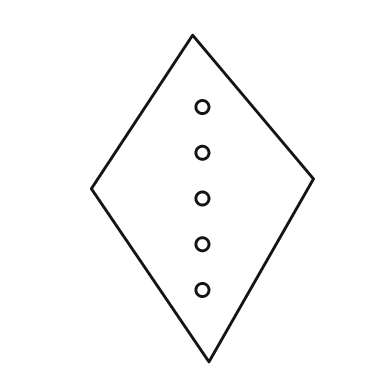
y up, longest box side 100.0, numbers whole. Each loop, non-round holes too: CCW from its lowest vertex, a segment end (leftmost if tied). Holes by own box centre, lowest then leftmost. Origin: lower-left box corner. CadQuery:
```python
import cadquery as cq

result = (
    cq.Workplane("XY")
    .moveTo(36.0, 0.0)
    .lineTo(68.0, 56.0)
    .lineTo(31.0, 100.0)
    .lineTo(0.0, 53.0)
    .close()
    .moveTo(34.0, 22.0)
    .circle(2.0)
    .moveTo(34.0, 36.0)
    .circle(2.0)
    .moveTo(34.0, 50.0)
    .circle(2.0)
    .moveTo(34.0, 64.0)
    .circle(2.0)
    .moveTo(34.0, 78.0)
    .circle(2.0)
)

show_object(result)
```